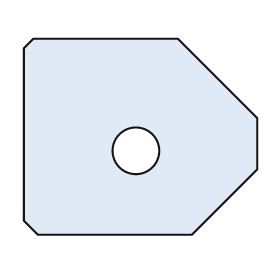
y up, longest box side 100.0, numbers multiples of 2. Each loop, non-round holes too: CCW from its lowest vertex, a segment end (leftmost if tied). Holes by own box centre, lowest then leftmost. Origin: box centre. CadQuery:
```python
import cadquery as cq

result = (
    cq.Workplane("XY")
    .moveTo(-44.0, -42.0)
    .lineTo(22.0, -42.0)
    .lineTo(50.0, -14.0)
    .lineTo(50.0, 8.0)
    .lineTo(16.0, 42.0)
    .lineTo(-46.0, 42.0)
    .lineTo(-50.0, 38.0)
    .lineTo(-50.0, -36.0)
    .close()
    .moveTo(-2.0, -6.0)
    .circle(10.0)
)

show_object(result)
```